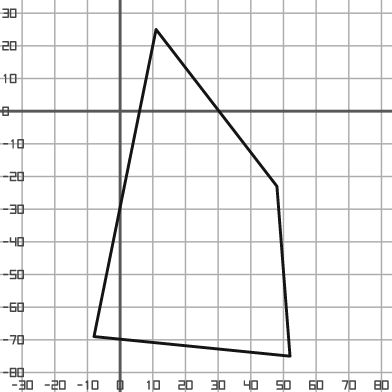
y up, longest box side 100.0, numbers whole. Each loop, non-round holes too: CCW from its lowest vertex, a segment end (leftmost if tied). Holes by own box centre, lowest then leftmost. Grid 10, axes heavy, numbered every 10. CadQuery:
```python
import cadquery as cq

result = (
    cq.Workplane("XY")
    .moveTo(52.0, -75.0)
    .lineTo(48.0, -23.0)
    .lineTo(11.0, 25.0)
    .lineTo(-8.0, -69.0)
    .close()
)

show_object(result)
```